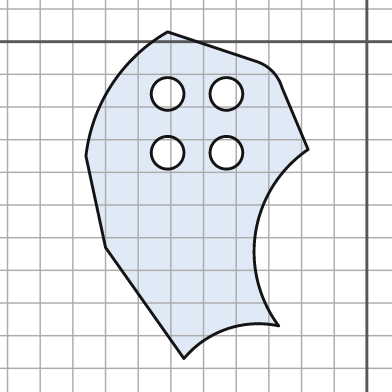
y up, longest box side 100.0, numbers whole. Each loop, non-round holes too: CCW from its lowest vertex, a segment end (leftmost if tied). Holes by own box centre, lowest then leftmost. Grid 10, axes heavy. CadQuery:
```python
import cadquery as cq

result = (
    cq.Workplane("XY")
    .moveTo(-56.0, -97.0)
    .threePointArc((-43.0, -88.0), (-27.0, -87.0))
    .threePointArc((-34.0, -58.0), (-18.0, -33.0))
    .lineTo(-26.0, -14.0)
    .threePointArc((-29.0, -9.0), (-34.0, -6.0))
    .lineTo(-61.0, 3.0)
    .threePointArc((-78.0, -13.0), (-86.0, -35.0))
    .lineTo(-80.0, -63.0)
    .close()
    .moveTo(-61.0, -34.0)
    .circle(5.0)
    .moveTo(-43.0, -34.0)
    .circle(5.0)
    .moveTo(-61.0, -16.0)
    .circle(5.0)
    .moveTo(-43.0, -16.0)
    .circle(5.0)
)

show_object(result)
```